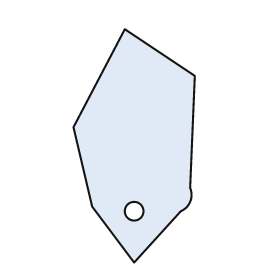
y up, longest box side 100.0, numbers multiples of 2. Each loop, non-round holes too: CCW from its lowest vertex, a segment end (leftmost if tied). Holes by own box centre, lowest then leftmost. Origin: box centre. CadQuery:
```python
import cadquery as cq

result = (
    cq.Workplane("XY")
    .moveTo(0.0, -50.0)
    .lineTo(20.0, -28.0)
    .threePointArc((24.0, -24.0), (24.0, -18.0))
    .lineTo(26.0, 30.0)
    .lineTo(-4.0, 50.0)
    .lineTo(-26.0, 8.0)
    .lineTo(-18.0, -26.0)
    .close()
    .moveTo(0.0, -28.0)
    .circle(4.0)
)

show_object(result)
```